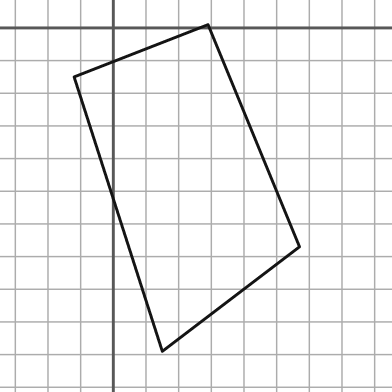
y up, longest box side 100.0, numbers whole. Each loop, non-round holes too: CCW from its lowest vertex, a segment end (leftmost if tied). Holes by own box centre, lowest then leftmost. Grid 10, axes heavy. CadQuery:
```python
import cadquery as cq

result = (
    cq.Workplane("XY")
    .moveTo(15.0, -99.0)
    .lineTo(57.0, -67.0)
    .lineTo(29.0, 1.0)
    .lineTo(-12.0, -15.0)
    .close()
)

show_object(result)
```